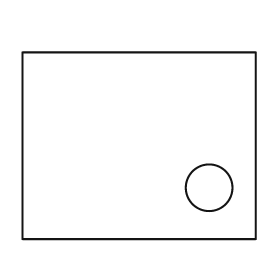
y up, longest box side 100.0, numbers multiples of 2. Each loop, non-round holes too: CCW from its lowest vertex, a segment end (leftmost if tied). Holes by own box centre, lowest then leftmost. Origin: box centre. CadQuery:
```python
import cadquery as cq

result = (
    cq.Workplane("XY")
    .moveTo(-50.0, -40.0)
    .lineTo(50.0, -40.0)
    .lineTo(50.0, 40.0)
    .lineTo(-50.0, 40.0)
    .close()
    .moveTo(30.0, -18.0)
    .circle(10.0)
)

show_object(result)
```